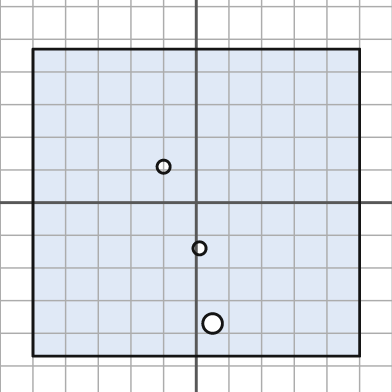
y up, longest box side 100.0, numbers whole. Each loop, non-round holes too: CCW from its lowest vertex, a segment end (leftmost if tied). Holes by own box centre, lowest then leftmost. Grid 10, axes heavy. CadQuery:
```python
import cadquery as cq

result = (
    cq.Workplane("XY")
    .moveTo(-50.0, -47.0)
    .lineTo(50.0, -47.0)
    .lineTo(50.0, 47.0)
    .lineTo(-50.0, 47.0)
    .close()
    .moveTo(5.0, -37.0)
    .circle(3.0)
    .moveTo(1.0, -14.0)
    .circle(2.0)
    .moveTo(-10.0, 11.0)
    .circle(2.0)
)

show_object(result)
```